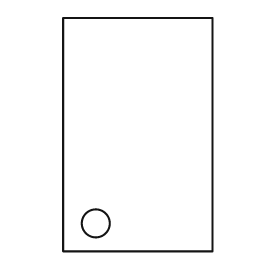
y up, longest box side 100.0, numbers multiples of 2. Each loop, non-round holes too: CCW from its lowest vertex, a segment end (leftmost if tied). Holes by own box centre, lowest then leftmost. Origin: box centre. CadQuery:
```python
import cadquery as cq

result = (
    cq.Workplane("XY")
    .moveTo(-32.0, -50.0)
    .lineTo(32.0, -50.0)
    .lineTo(32.0, 50.0)
    .lineTo(-32.0, 50.0)
    .close()
    .moveTo(-18.0, -38.0)
    .circle(6.0)
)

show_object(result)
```